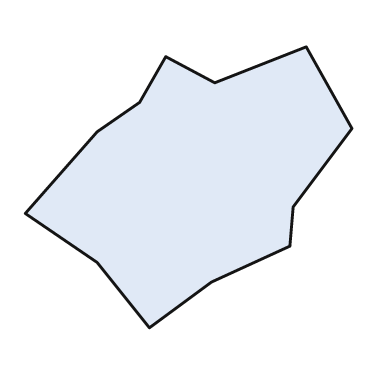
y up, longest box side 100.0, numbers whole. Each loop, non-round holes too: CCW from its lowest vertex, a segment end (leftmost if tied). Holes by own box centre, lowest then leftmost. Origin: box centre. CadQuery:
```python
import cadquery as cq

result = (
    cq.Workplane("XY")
    .moveTo(-12.0, -43.0)
    .lineTo(7.0, -29.0)
    .lineTo(31.0, -18.0)
    .lineTo(32.0, -6.0)
    .lineTo(50.0, 18.0)
    .lineTo(36.0, 43.0)
    .lineTo(8.0, 32.0)
    .lineTo(-7.0, 40.0)
    .lineTo(-15.0, 26.0)
    .lineTo(-28.0, 17.0)
    .lineTo(-50.0, -8.0)
    .lineTo(-28.0, -23.0)
    .close()
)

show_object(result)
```